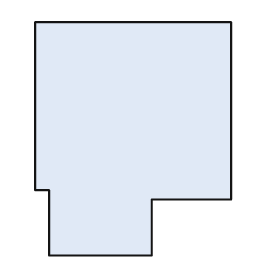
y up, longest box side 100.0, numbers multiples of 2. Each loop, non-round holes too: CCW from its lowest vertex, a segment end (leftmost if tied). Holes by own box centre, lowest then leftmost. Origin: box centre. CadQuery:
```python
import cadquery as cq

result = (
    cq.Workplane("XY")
    .moveTo(-36.0, -50.0)
    .lineTo(8.0, -50.0)
    .lineTo(8.0, -26.0)
    .lineTo(42.0, -26.0)
    .lineTo(42.0, 50.0)
    .lineTo(-42.0, 50.0)
    .lineTo(-42.0, -22.0)
    .lineTo(-36.0, -22.0)
    .close()
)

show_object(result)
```